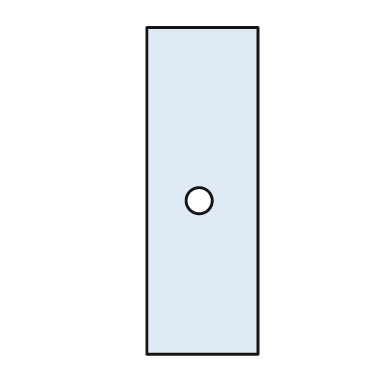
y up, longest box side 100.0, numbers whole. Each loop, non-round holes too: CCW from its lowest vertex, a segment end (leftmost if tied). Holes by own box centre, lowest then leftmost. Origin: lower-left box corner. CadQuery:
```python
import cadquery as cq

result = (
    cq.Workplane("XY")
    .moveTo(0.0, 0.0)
    .lineTo(34.0, 0.0)
    .lineTo(34.0, 100.0)
    .lineTo(0.0, 100.0)
    .close()
    .moveTo(16.0, 47.0)
    .circle(4.0)
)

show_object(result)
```